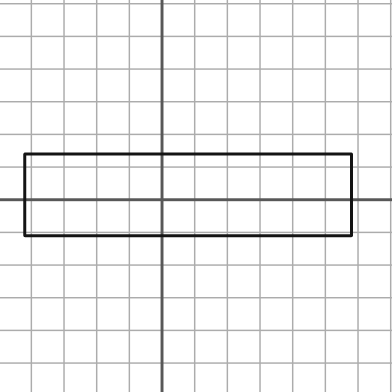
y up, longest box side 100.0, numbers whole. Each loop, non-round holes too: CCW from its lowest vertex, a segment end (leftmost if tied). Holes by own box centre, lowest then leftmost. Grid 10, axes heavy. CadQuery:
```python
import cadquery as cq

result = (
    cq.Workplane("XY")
    .moveTo(-42.0, -11.0)
    .lineTo(58.0, -11.0)
    .lineTo(58.0, 14.0)
    .lineTo(-42.0, 14.0)
    .close()
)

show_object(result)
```